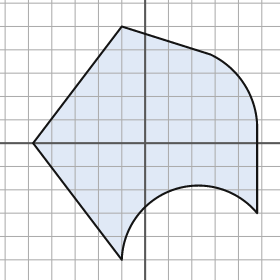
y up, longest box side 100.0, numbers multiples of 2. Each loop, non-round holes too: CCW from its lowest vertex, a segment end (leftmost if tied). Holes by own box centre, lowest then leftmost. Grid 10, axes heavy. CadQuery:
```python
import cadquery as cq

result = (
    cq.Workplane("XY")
    .moveTo(-10.0, -50.0)
    .threePointArc((12.0, -20.0), (48.0, -30.0))
    .lineTo(48.0, 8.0)
    .threePointArc((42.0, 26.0), (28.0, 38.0))
    .lineTo(-10.0, 50.0)
    .lineTo(-48.0, 0.0)
    .close()
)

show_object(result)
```